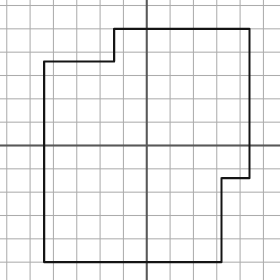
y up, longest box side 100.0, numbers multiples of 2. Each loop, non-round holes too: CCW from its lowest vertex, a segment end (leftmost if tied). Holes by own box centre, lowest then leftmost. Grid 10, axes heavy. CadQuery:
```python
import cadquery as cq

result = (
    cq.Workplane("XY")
    .moveTo(-44.0, -50.0)
    .lineTo(32.0, -50.0)
    .lineTo(32.0, -14.0)
    .lineTo(44.0, -14.0)
    .lineTo(44.0, 50.0)
    .lineTo(-14.0, 50.0)
    .lineTo(-14.0, 36.0)
    .lineTo(-44.0, 36.0)
    .close()
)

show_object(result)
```